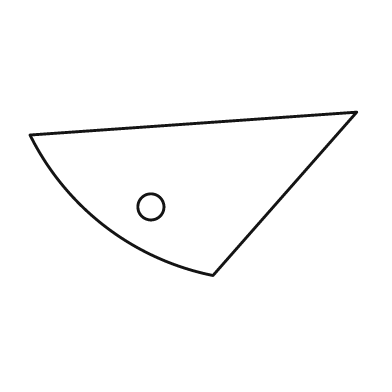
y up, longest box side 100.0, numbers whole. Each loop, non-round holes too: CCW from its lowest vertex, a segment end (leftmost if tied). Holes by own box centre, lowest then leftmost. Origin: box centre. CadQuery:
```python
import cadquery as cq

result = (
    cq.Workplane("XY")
    .moveTo(6.0, -25.0)
    .lineTo(50.0, 25.0)
    .lineTo(-50.0, 18.0)
    .threePointArc((-27.0, -10.0), (6.0, -25.0))
    .close()
    .moveTo(-13.0, -4.0)
    .circle(4.0)
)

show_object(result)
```